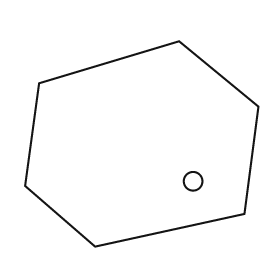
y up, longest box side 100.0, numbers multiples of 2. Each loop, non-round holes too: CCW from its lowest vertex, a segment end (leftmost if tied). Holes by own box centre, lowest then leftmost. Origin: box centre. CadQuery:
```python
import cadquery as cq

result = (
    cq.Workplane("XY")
    .moveTo(-20.0, -44.0)
    .lineTo(44.0, -30.0)
    .lineTo(50.0, 16.0)
    .lineTo(16.0, 44.0)
    .lineTo(-44.0, 26.0)
    .lineTo(-50.0, -18.0)
    .close()
    .moveTo(22.0, -16.0)
    .circle(4.0)
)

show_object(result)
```